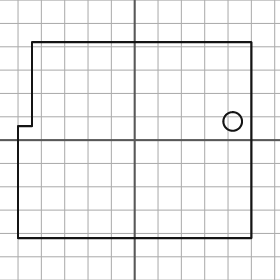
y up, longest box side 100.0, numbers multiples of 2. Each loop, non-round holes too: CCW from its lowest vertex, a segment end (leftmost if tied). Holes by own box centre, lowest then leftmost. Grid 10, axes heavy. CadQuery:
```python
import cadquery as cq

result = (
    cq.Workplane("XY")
    .moveTo(-50.0, -42.0)
    .lineTo(50.0, -42.0)
    .lineTo(50.0, 42.0)
    .lineTo(-44.0, 42.0)
    .lineTo(-44.0, 6.0)
    .lineTo(-50.0, 6.0)
    .close()
    .moveTo(42.0, 8.0)
    .circle(4.0)
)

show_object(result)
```